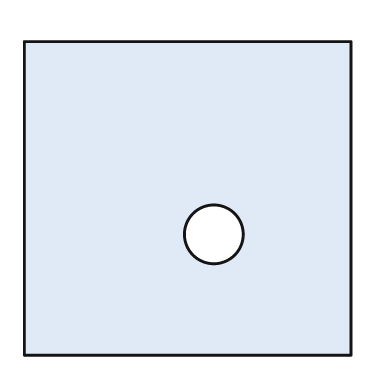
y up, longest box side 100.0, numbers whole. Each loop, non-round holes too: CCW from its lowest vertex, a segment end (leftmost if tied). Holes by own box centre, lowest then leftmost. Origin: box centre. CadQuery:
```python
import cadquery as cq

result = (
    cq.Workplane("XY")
    .moveTo(-50.0, -48.0)
    .lineTo(50.0, -48.0)
    .lineTo(50.0, 48.0)
    .lineTo(-50.0, 48.0)
    .close()
    .moveTo(8.0, -11.0)
    .circle(9.0)
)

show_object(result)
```